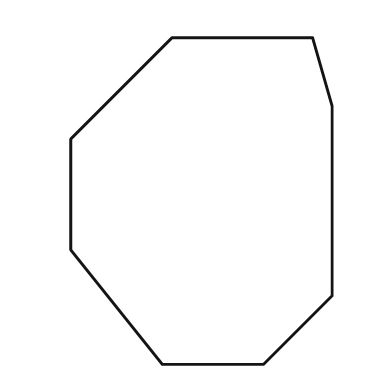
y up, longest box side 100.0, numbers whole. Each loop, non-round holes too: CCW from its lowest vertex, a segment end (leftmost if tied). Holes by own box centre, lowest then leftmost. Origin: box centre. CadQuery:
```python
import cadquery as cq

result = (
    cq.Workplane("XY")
    .moveTo(-12.0, -50.0)
    .lineTo(19.0, -50.0)
    .lineTo(40.0, -29.0)
    .lineTo(40.0, 29.0)
    .lineTo(34.0, 50.0)
    .lineTo(-9.0, 50.0)
    .lineTo(-40.0, 19.0)
    .lineTo(-40.0, -15.0)
    .close()
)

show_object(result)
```